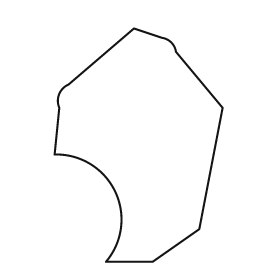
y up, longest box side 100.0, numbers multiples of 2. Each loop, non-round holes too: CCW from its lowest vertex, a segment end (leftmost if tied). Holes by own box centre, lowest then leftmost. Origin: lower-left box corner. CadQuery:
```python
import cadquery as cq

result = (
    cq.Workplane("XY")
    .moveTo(22.0, 0.0)
    .lineTo(42.0, 0.0)
    .lineTo(62.0, 14.0)
    .lineTo(72.0, 66.0)
    .lineTo(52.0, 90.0)
    .threePointArc((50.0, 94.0), (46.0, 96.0))
    .lineTo(34.0, 100.0)
    .lineTo(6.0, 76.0)
    .threePointArc((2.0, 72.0), (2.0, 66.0))
    .lineTo(0.0, 46.0)
    .threePointArc((26.0, 30.0), (22.0, 0.0))
    .close()
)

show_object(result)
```